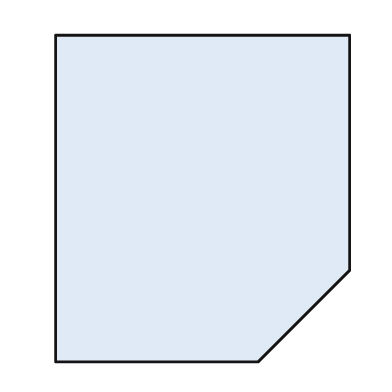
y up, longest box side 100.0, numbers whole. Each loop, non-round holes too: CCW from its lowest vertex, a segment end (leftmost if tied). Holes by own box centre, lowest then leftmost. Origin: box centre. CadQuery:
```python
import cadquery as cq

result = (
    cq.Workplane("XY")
    .moveTo(-45.0, -50.0)
    .lineTo(17.0, -50.0)
    .lineTo(45.0, -22.0)
    .lineTo(45.0, 50.0)
    .lineTo(-45.0, 50.0)
    .close()
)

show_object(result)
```